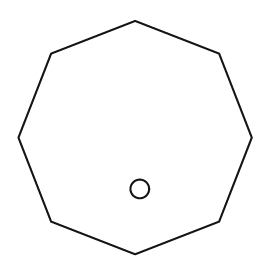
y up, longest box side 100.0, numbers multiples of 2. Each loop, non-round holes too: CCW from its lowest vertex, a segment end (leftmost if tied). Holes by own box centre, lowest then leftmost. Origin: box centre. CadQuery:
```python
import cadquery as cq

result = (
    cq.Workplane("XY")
    .moveTo(0.0, -50.0)
    .lineTo(36.0, -36.0)
    .lineTo(50.0, 0.0)
    .lineTo(36.0, 36.0)
    .lineTo(0.0, 50.0)
    .lineTo(-36.0, 36.0)
    .lineTo(-50.0, 0.0)
    .lineTo(-36.0, -36.0)
    .close()
    .moveTo(2.0, -22.0)
    .circle(4.0)
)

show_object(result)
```